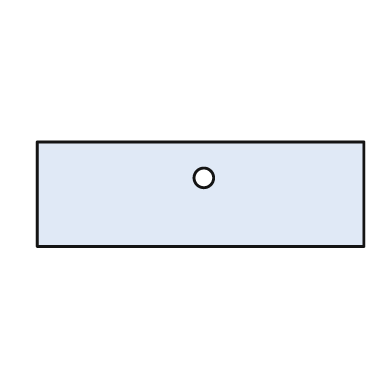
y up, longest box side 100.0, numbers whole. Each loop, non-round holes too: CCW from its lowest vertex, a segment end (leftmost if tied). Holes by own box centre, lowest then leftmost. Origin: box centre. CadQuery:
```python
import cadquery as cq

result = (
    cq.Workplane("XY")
    .moveTo(-50.0, -16.0)
    .lineTo(50.0, -16.0)
    .lineTo(50.0, 16.0)
    .lineTo(-50.0, 16.0)
    .close()
    .moveTo(1.0, 5.0)
    .circle(3.0)
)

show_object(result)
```